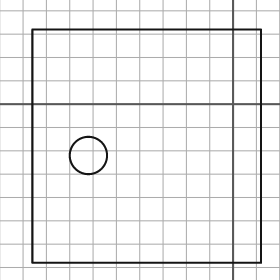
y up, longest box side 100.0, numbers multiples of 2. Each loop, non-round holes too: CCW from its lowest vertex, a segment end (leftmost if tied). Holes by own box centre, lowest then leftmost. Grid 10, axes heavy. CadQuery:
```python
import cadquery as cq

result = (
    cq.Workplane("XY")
    .moveTo(-86.0, -68.0)
    .lineTo(12.0, -68.0)
    .lineTo(12.0, 32.0)
    .lineTo(-86.0, 32.0)
    .close()
    .moveTo(-62.0, -22.0)
    .circle(8.0)
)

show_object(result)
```